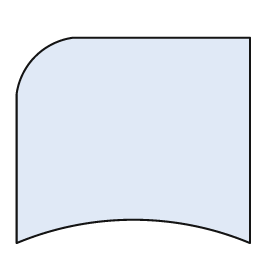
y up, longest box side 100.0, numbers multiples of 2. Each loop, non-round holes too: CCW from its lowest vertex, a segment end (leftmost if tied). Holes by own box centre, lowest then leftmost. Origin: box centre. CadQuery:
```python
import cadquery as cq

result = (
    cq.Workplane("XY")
    .moveTo(-50.0, -44.0)
    .threePointArc((0.0, -34.0), (50.0, -44.0))
    .lineTo(50.0, 44.0)
    .lineTo(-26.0, 44.0)
    .threePointArc((-42.0, 36.0), (-50.0, 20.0))
    .close()
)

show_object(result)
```